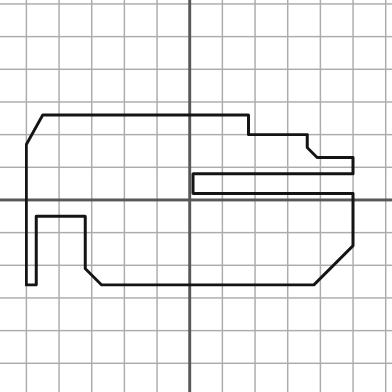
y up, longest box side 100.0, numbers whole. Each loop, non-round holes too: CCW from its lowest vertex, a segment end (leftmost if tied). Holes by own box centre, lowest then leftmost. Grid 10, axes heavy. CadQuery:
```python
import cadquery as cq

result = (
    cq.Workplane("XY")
    .moveTo(-50.0, -26.0)
    .lineTo(-47.0, -26.0)
    .lineTo(-47.0, -5.0)
    .lineTo(-32.0, -5.0)
    .lineTo(-32.0, -21.0)
    .lineTo(-27.0, -26.0)
    .lineTo(38.0, -26.0)
    .lineTo(50.0, -14.0)
    .lineTo(50.0, 2.0)
    .lineTo(1.0, 2.0)
    .lineTo(1.0, 8.0)
    .lineTo(50.0, 8.0)
    .lineTo(50.0, 13.0)
    .lineTo(39.0, 13.0)
    .lineTo(36.0, 16.0)
    .lineTo(36.0, 20.0)
    .lineTo(18.0, 20.0)
    .lineTo(18.0, 26.0)
    .lineTo(-45.0, 26.0)
    .lineTo(-50.0, 17.0)
    .close()
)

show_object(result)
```